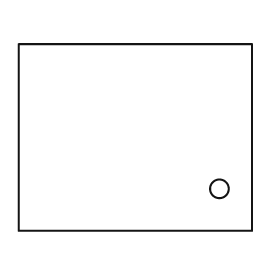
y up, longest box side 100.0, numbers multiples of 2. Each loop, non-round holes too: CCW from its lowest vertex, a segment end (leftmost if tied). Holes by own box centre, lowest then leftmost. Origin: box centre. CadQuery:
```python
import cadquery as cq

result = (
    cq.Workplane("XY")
    .moveTo(-50.0, -40.0)
    .lineTo(50.0, -40.0)
    .lineTo(50.0, 40.0)
    .lineTo(-50.0, 40.0)
    .close()
    .moveTo(36.0, -22.0)
    .circle(4.0)
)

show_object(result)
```